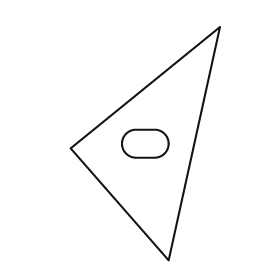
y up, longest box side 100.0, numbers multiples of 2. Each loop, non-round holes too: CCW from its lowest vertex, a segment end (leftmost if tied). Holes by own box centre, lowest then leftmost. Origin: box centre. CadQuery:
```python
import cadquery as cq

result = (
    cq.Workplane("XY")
    .moveTo(10.0, -50.0)
    .lineTo(32.0, 50.0)
    .lineTo(-32.0, -2.0)
    .close()
    .moveTo(-4.0, -6.0)
    .lineTo(4.0, -6.0)
    .threePointArc((10.0, 0.0), (4.0, 6.0))
    .lineTo(-4.0, 6.0)
    .threePointArc((-10.0, 0.0), (-4.0, -6.0))
    .close()
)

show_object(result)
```